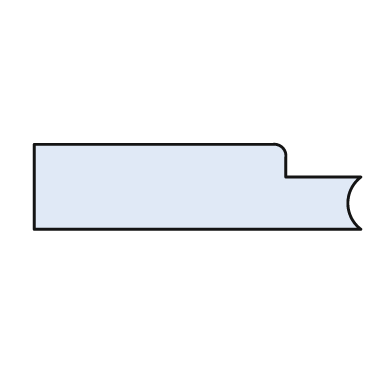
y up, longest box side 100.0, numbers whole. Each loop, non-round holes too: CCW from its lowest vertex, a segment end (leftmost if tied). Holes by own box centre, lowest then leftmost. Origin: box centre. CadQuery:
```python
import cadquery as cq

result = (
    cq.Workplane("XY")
    .moveTo(-50.0, -13.0)
    .lineTo(50.0, -13.0)
    .threePointArc((46.0, -5.0), (50.0, 3.0))
    .lineTo(27.0, 3.0)
    .lineTo(27.0, 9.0)
    .threePointArc((26.0, 12.0), (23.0, 13.0))
    .lineTo(-50.0, 13.0)
    .close()
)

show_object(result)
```